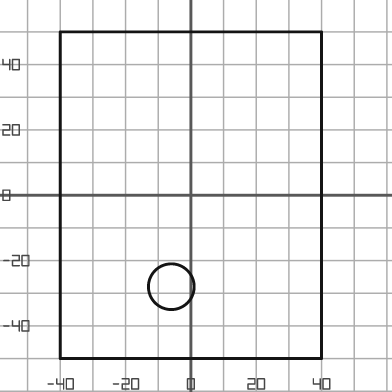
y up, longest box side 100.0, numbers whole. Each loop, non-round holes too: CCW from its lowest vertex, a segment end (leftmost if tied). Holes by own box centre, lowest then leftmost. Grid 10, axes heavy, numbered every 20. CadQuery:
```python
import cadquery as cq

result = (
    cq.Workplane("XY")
    .moveTo(-40.0, -50.0)
    .lineTo(40.0, -50.0)
    .lineTo(40.0, 50.0)
    .lineTo(-40.0, 50.0)
    .close()
    .moveTo(-6.0, -28.0)
    .circle(7.0)
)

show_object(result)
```